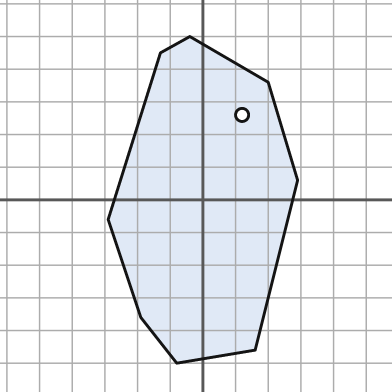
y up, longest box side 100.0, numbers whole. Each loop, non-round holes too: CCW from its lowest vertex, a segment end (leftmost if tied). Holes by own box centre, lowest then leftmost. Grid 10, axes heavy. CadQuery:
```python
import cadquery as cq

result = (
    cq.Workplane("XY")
    .moveTo(-8.0, -50.0)
    .lineTo(16.0, -46.0)
    .lineTo(29.0, 6.0)
    .lineTo(20.0, 36.0)
    .lineTo(-4.0, 50.0)
    .lineTo(-13.0, 45.0)
    .lineTo(-29.0, -6.0)
    .lineTo(-19.0, -36.0)
    .close()
    .moveTo(12.0, 26.0)
    .circle(2.0)
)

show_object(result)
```